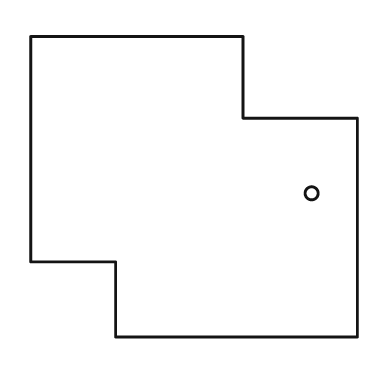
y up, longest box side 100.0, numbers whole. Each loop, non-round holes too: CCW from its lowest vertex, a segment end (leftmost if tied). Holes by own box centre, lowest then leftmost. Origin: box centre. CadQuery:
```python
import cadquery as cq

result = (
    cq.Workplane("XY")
    .moveTo(-24.0, -46.0)
    .lineTo(50.0, -46.0)
    .lineTo(50.0, 21.0)
    .lineTo(15.0, 21.0)
    .lineTo(15.0, 46.0)
    .lineTo(-50.0, 46.0)
    .lineTo(-50.0, -23.0)
    .lineTo(-24.0, -23.0)
    .close()
    .moveTo(36.0, -2.0)
    .circle(2.0)
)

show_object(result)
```